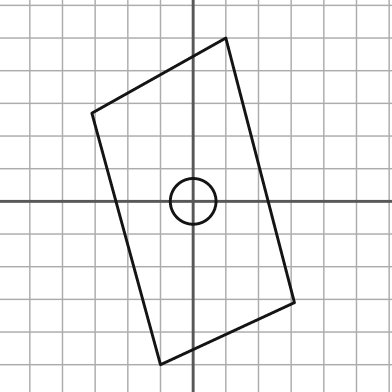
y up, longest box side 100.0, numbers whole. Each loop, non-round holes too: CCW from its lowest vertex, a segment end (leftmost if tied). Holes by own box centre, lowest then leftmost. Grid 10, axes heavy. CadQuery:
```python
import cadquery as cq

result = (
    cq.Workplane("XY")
    .moveTo(-10.0, -50.0)
    .lineTo(31.0, -31.0)
    .lineTo(10.0, 50.0)
    .lineTo(-31.0, 27.0)
    .close()
    .moveTo(0.0, 0.0)
    .circle(7.0)
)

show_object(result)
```